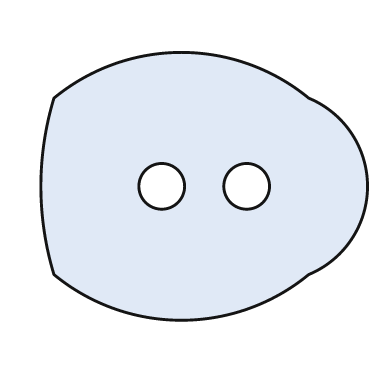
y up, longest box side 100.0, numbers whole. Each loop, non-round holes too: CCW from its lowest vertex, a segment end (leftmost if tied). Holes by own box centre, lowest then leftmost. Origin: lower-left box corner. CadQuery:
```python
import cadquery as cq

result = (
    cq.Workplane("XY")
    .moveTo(4.0, 14.0)
    .threePointArc((43.0, 0.0), (82.0, 14.0))
    .threePointArc((100.0, 41.0), (82.0, 68.0))
    .threePointArc((43.0, 82.0), (4.0, 68.0))
    .threePointArc((0.0, 41.0), (4.0, 14.0))
    .close()
    .moveTo(37.0, 41.0)
    .circle(7.0)
    .moveTo(63.0, 41.0)
    .circle(7.0)
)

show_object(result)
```